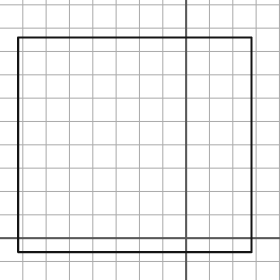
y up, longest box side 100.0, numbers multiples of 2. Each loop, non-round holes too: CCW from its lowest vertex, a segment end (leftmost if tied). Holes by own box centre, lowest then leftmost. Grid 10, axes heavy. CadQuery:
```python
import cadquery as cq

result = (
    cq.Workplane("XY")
    .moveTo(-72.0, -6.0)
    .lineTo(28.0, -6.0)
    .lineTo(28.0, 86.0)
    .lineTo(-72.0, 86.0)
    .close()
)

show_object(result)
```